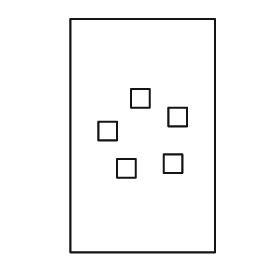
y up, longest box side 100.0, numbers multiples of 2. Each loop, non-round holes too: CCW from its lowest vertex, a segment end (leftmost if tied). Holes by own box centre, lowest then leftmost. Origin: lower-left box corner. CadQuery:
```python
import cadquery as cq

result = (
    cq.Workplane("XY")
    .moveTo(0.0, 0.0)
    .lineTo(62.0, 0.0)
    .lineTo(62.0, 100.0)
    .lineTo(0.0, 100.0)
    .close()
    .moveTo(20.0, 32.0)
    .lineTo(28.0, 32.0)
    .lineTo(28.0, 40.0)
    .lineTo(20.0, 40.0)
    .close()
    .moveTo(40.0, 34.0)
    .lineTo(48.0, 34.0)
    .lineTo(48.0, 42.0)
    .lineTo(40.0, 42.0)
    .close()
    .moveTo(12.0, 48.0)
    .lineTo(20.0, 48.0)
    .lineTo(20.0, 56.0)
    .lineTo(12.0, 56.0)
    .close()
    .moveTo(42.0, 54.0)
    .lineTo(50.0, 54.0)
    .lineTo(50.0, 62.0)
    .lineTo(42.0, 62.0)
    .close()
    .moveTo(26.0, 62.0)
    .lineTo(34.0, 62.0)
    .lineTo(34.0, 70.0)
    .lineTo(26.0, 70.0)
    .close()
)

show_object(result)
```